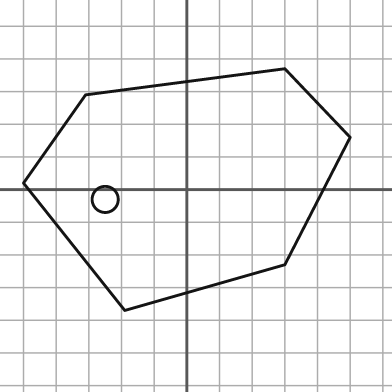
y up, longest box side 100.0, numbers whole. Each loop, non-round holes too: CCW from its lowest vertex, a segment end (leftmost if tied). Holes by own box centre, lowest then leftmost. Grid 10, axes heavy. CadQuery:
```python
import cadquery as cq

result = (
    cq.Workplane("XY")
    .moveTo(-19.0, -37.0)
    .lineTo(30.0, -23.0)
    .lineTo(50.0, 16.0)
    .lineTo(30.0, 37.0)
    .lineTo(-31.0, 29.0)
    .lineTo(-50.0, 2.0)
    .close()
    .moveTo(-25.0, -3.0)
    .circle(4.0)
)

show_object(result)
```